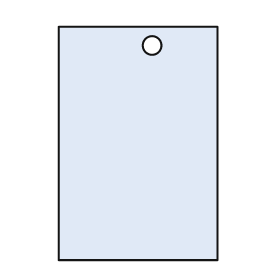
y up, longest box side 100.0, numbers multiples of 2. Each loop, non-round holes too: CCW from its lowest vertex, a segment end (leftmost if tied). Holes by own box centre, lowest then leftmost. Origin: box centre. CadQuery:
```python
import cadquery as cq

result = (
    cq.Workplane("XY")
    .moveTo(-34.0, -50.0)
    .lineTo(34.0, -50.0)
    .lineTo(34.0, 50.0)
    .lineTo(-34.0, 50.0)
    .close()
    .moveTo(6.0, 42.0)
    .circle(4.0)
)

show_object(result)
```